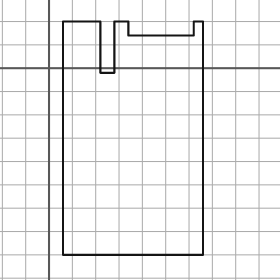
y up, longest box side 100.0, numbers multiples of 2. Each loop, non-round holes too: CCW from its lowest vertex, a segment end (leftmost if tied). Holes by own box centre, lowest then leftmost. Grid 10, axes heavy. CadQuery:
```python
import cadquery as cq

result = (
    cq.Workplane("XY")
    .moveTo(6.0, -80.0)
    .lineTo(66.0, -80.0)
    .lineTo(66.0, 20.0)
    .lineTo(62.0, 20.0)
    .lineTo(62.0, 14.0)
    .lineTo(34.0, 14.0)
    .lineTo(34.0, 20.0)
    .lineTo(28.0, 20.0)
    .lineTo(28.0, -2.0)
    .lineTo(22.0, -2.0)
    .lineTo(22.0, 20.0)
    .lineTo(6.0, 20.0)
    .close()
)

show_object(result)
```